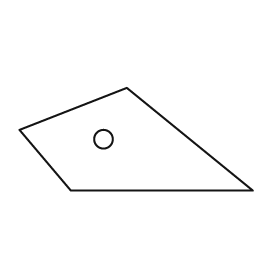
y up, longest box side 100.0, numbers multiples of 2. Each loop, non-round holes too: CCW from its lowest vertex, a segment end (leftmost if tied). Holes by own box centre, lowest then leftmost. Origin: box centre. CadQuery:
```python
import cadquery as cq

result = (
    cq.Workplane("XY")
    .moveTo(-28.0, -22.0)
    .lineTo(50.0, -22.0)
    .lineTo(-4.0, 22.0)
    .lineTo(-50.0, 4.0)
    .close()
    .moveTo(-14.0, 0.0)
    .circle(4.0)
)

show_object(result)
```